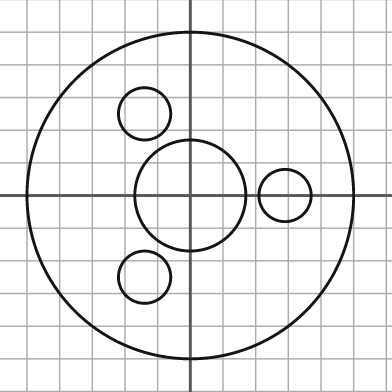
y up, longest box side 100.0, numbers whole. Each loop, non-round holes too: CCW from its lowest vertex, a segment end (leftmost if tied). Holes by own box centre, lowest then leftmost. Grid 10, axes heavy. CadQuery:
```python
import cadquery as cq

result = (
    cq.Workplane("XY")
    .moveTo(0.0, 0.0)
    .circle(50.0)
    .moveTo(-14.0, -25.0)
    .circle(8.0)
    .moveTo(0.0, 0.0)
    .circle(17.0)
    .moveTo(29.0, 0.0)
    .circle(8.0)
    .moveTo(-14.0, 25.0)
    .circle(8.0)
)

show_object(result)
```